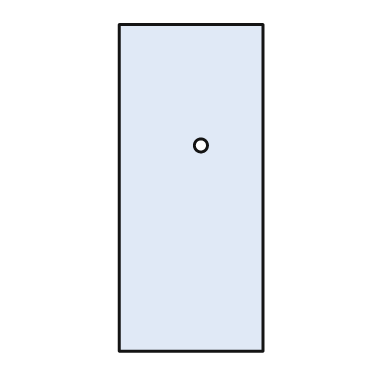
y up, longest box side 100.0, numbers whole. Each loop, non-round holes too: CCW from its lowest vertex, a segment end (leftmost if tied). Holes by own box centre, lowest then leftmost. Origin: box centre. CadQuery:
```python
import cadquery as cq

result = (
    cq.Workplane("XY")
    .moveTo(-22.0, -50.0)
    .lineTo(22.0, -50.0)
    .lineTo(22.0, 50.0)
    .lineTo(-22.0, 50.0)
    .close()
    .moveTo(3.0, 13.0)
    .circle(2.0)
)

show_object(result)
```